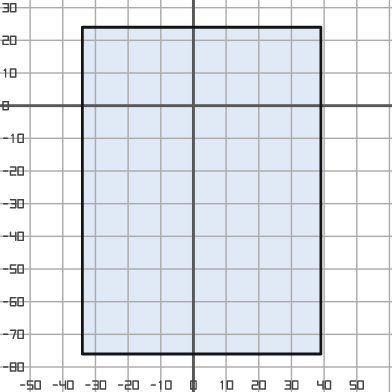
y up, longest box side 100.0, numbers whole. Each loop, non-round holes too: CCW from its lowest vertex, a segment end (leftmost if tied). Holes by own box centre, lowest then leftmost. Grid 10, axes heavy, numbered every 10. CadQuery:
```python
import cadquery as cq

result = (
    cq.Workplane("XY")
    .moveTo(-34.0, -76.0)
    .lineTo(39.0, -76.0)
    .lineTo(39.0, 24.0)
    .lineTo(-34.0, 24.0)
    .close()
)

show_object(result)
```